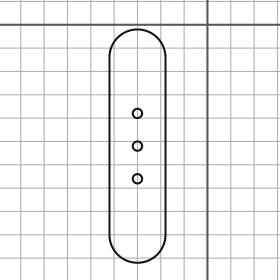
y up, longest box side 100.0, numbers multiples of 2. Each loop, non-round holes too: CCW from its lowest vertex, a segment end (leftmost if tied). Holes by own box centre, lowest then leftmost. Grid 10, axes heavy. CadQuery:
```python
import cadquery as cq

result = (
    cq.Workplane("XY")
    .moveTo(-42.0, -90.0)
    .threePointArc((-30.0, -102.0), (-18.0, -90.0))
    .lineTo(-18.0, -14.0)
    .threePointArc((-30.0, -2.0), (-42.0, -14.0))
    .close()
    .moveTo(-30.0, -66.0)
    .circle(2.0)
    .moveTo(-30.0, -52.0)
    .circle(2.0)
    .moveTo(-30.0, -38.0)
    .circle(2.0)
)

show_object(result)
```